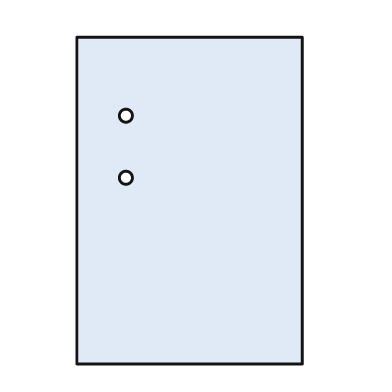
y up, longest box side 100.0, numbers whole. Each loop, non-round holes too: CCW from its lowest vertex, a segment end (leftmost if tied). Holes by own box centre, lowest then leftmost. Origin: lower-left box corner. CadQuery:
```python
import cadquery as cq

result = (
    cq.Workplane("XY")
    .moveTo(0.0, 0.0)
    .lineTo(69.0, 0.0)
    .lineTo(69.0, 100.0)
    .lineTo(0.0, 100.0)
    .close()
    .moveTo(15.0, 57.0)
    .circle(2.0)
    .moveTo(15.0, 76.0)
    .circle(2.0)
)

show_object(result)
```